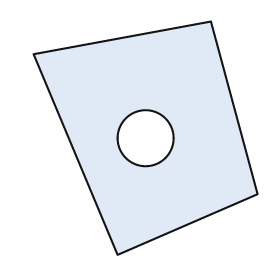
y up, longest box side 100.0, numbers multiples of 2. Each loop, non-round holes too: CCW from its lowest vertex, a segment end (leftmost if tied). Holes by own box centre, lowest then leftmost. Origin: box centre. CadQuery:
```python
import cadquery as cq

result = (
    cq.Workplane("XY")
    .moveTo(-12.0, -50.0)
    .lineTo(48.0, -24.0)
    .lineTo(28.0, 50.0)
    .lineTo(-48.0, 36.0)
    .close()
    .moveTo(0.0, 0.0)
    .circle(12.0)
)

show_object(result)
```